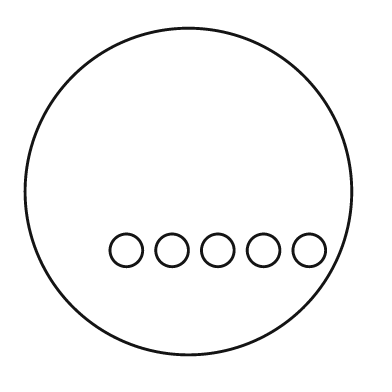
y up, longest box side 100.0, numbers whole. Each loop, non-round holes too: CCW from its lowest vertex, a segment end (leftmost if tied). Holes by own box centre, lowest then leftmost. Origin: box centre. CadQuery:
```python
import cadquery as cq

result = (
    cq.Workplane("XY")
    .moveTo(0.0, 0.0)
    .circle(50.0)
    .moveTo(-19.0, -18.0)
    .circle(5.0)
    .moveTo(-5.0, -18.0)
    .circle(5.0)
    .moveTo(9.0, -18.0)
    .circle(5.0)
    .moveTo(23.0, -18.0)
    .circle(5.0)
    .moveTo(37.0, -18.0)
    .circle(5.0)
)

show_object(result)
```